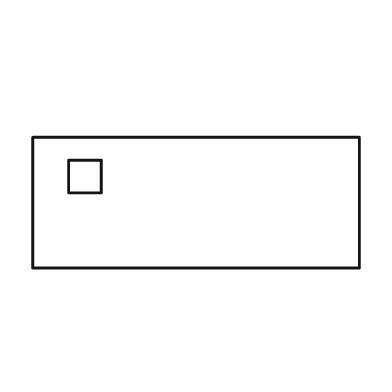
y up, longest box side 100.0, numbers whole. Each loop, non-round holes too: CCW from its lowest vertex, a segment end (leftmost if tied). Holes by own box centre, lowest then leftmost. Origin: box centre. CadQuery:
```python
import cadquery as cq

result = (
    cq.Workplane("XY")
    .moveTo(-50.0, -20.0)
    .lineTo(50.0, -20.0)
    .lineTo(50.0, 20.0)
    .lineTo(-50.0, 20.0)
    .close()
    .moveTo(-39.0, 3.0)
    .lineTo(-29.0, 3.0)
    .lineTo(-29.0, 13.0)
    .lineTo(-39.0, 13.0)
    .close()
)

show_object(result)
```